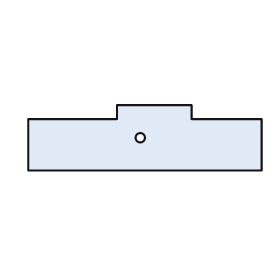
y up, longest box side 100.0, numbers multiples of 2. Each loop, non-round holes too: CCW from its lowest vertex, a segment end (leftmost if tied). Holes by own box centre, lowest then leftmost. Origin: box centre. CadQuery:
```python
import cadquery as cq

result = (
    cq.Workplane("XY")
    .moveTo(-50.0, -14.0)
    .lineTo(50.0, -14.0)
    .lineTo(50.0, 8.0)
    .lineTo(20.0, 8.0)
    .lineTo(20.0, 14.0)
    .lineTo(-12.0, 14.0)
    .lineTo(-12.0, 8.0)
    .lineTo(-50.0, 8.0)
    .close()
    .moveTo(-2.0, 0.0)
    .circle(2.0)
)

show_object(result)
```